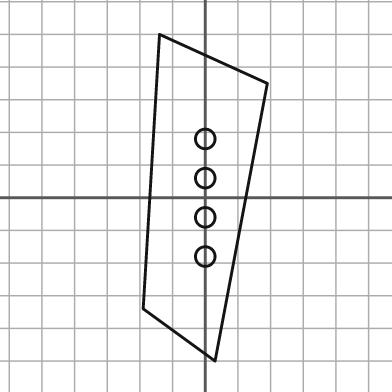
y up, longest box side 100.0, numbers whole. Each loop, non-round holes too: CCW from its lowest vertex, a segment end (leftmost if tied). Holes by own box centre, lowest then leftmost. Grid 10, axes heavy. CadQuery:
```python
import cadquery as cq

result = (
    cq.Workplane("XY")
    .moveTo(3.0, -50.0)
    .lineTo(19.0, 35.0)
    .lineTo(-14.0, 50.0)
    .lineTo(-19.0, -34.0)
    .close()
    .moveTo(0.0, -18.0)
    .circle(3.0)
    .moveTo(0.0, -6.0)
    .circle(3.0)
    .moveTo(0.0, 6.0)
    .circle(3.0)
    .moveTo(0.0, 18.0)
    .circle(3.0)
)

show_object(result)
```